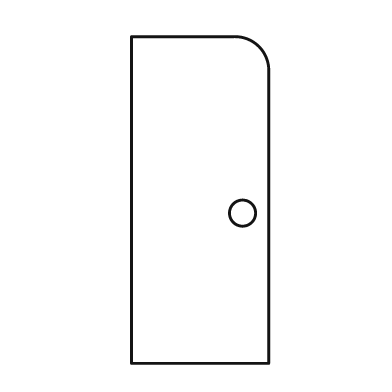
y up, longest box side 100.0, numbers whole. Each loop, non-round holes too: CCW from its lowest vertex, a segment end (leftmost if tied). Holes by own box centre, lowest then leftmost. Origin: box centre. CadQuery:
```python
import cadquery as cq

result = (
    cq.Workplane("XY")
    .moveTo(-21.0, -50.0)
    .lineTo(21.0, -50.0)
    .lineTo(21.0, 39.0)
    .threePointArc((18.0, 47.0), (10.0, 50.0))
    .lineTo(-21.0, 50.0)
    .close()
    .moveTo(13.0, -4.0)
    .circle(4.0)
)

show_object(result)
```